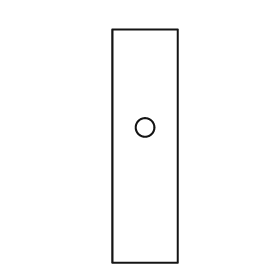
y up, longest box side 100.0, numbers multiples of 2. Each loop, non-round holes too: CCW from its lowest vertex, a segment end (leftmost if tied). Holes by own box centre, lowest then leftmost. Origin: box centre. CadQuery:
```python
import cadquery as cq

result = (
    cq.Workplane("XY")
    .moveTo(-14.0, -50.0)
    .lineTo(14.0, -50.0)
    .lineTo(14.0, 50.0)
    .lineTo(-14.0, 50.0)
    .close()
    .moveTo(0.0, 8.0)
    .circle(4.0)
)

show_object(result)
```